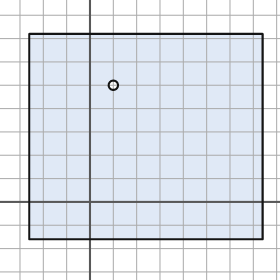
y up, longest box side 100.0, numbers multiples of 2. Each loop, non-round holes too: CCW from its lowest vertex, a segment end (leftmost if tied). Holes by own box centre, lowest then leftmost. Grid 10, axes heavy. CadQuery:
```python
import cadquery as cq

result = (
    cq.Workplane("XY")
    .moveTo(-26.0, -16.0)
    .lineTo(74.0, -16.0)
    .lineTo(74.0, 72.0)
    .lineTo(-26.0, 72.0)
    .close()
    .moveTo(10.0, 50.0)
    .circle(2.0)
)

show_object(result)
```